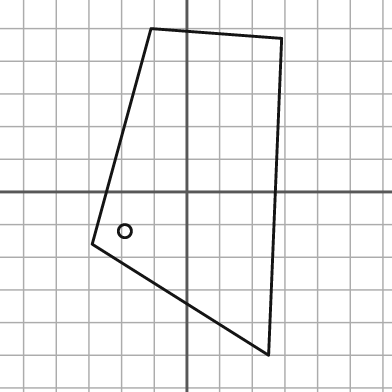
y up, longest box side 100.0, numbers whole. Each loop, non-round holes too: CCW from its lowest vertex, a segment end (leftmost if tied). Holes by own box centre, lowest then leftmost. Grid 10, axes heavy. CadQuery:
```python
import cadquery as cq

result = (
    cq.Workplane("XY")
    .moveTo(25.0, -50.0)
    .lineTo(29.0, 47.0)
    .lineTo(-11.0, 50.0)
    .lineTo(-29.0, -16.0)
    .close()
    .moveTo(-19.0, -12.0)
    .circle(2.0)
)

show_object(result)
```